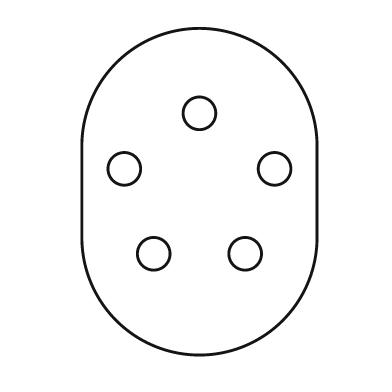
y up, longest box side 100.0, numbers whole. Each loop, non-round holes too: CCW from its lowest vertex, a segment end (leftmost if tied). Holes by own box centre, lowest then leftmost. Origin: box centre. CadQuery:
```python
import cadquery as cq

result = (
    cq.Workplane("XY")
    .moveTo(-36.0, -14.0)
    .threePointArc((0.0, -50.0), (36.0, -14.0))
    .lineTo(36.0, 14.0)
    .threePointArc((0.0, 50.0), (-36.0, 14.0))
    .close()
    .moveTo(-14.0, -19.0)
    .circle(5.0)
    .moveTo(14.0, -19.0)
    .circle(5.0)
    .moveTo(-23.0, 7.0)
    .circle(5.0)
    .moveTo(23.0, 7.0)
    .circle(5.0)
    .moveTo(0.0, 24.0)
    .circle(5.0)
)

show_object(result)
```